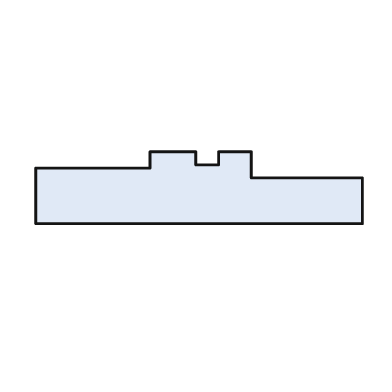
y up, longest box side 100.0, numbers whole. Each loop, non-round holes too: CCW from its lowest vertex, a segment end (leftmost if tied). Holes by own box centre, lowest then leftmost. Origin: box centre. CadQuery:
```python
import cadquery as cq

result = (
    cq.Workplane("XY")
    .moveTo(-50.0, -11.0)
    .lineTo(50.0, -11.0)
    .lineTo(50.0, 3.0)
    .lineTo(16.0, 3.0)
    .lineTo(16.0, 11.0)
    .lineTo(6.0, 11.0)
    .lineTo(6.0, 7.0)
    .lineTo(-1.0, 7.0)
    .lineTo(-1.0, 11.0)
    .lineTo(-15.0, 11.0)
    .lineTo(-15.0, 6.0)
    .lineTo(-50.0, 6.0)
    .close()
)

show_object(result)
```